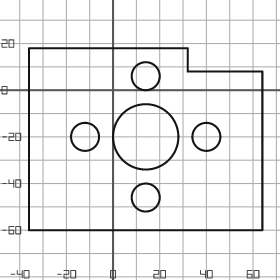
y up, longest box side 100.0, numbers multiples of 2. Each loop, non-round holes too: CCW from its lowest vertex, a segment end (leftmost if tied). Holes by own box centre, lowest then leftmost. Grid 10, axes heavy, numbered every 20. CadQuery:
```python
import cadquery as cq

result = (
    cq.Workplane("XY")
    .moveTo(-36.0, -60.0)
    .lineTo(64.0, -60.0)
    .lineTo(64.0, 8.0)
    .lineTo(32.0, 8.0)
    .lineTo(32.0, 18.0)
    .lineTo(-36.0, 18.0)
    .close()
    .moveTo(14.0, -46.0)
    .circle(6.0)
    .moveTo(-12.0, -20.0)
    .circle(6.0)
    .moveTo(14.0, -20.0)
    .circle(14.0)
    .moveTo(40.0, -20.0)
    .circle(6.0)
    .moveTo(14.0, 6.0)
    .circle(6.0)
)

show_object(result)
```